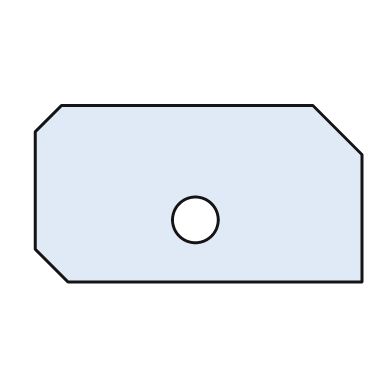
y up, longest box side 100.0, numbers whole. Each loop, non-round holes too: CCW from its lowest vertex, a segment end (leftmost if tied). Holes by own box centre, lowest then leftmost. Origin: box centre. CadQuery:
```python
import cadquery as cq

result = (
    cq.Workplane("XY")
    .moveTo(-40.0, -27.0)
    .lineTo(50.0, -27.0)
    .lineTo(50.0, 12.0)
    .lineTo(35.0, 27.0)
    .lineTo(-42.0, 27.0)
    .lineTo(-50.0, 19.0)
    .lineTo(-50.0, -17.0)
    .close()
    .moveTo(-1.0, -8.0)
    .circle(7.0)
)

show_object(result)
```